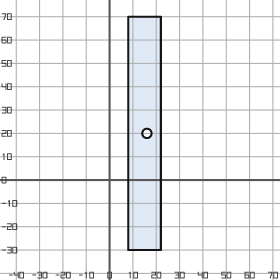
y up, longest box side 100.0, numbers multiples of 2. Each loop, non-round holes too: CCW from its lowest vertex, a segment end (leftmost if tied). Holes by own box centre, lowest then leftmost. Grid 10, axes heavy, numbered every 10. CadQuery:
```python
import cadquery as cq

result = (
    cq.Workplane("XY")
    .moveTo(8.0, -30.0)
    .lineTo(22.0, -30.0)
    .lineTo(22.0, 70.0)
    .lineTo(8.0, 70.0)
    .close()
    .moveTo(16.0, 20.0)
    .circle(2.0)
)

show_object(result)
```